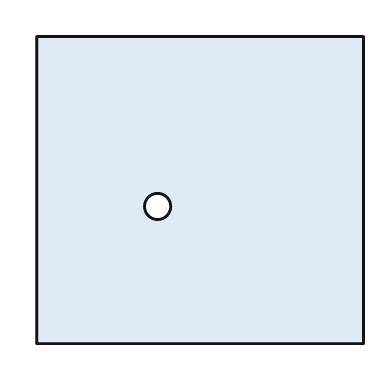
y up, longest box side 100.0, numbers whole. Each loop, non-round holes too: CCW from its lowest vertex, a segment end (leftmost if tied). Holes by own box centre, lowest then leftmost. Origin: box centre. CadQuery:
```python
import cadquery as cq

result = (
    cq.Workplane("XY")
    .moveTo(-50.0, -47.0)
    .lineTo(50.0, -47.0)
    .lineTo(50.0, 47.0)
    .lineTo(-50.0, 47.0)
    .close()
    .moveTo(-13.0, -5.0)
    .circle(4.0)
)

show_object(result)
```